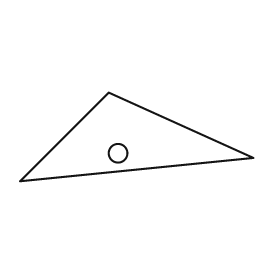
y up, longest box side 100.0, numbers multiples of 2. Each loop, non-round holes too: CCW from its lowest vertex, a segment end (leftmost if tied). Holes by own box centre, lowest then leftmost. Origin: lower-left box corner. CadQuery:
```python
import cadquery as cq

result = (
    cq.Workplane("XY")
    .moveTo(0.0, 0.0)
    .lineTo(100.0, 10.0)
    .lineTo(38.0, 38.0)
    .close()
    .moveTo(42.0, 12.0)
    .circle(4.0)
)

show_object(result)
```